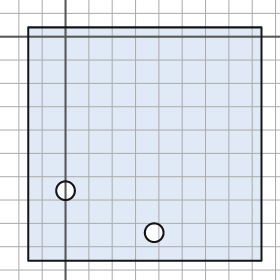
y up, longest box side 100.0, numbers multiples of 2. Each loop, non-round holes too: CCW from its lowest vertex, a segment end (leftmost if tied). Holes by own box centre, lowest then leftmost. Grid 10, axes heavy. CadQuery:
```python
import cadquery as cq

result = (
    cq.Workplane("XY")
    .moveTo(-16.0, -96.0)
    .lineTo(84.0, -96.0)
    .lineTo(84.0, 4.0)
    .lineTo(-16.0, 4.0)
    .close()
    .moveTo(38.0, -84.0)
    .circle(4.0)
    .moveTo(0.0, -66.0)
    .circle(4.0)
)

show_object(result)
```